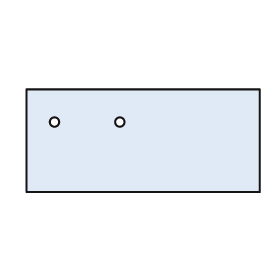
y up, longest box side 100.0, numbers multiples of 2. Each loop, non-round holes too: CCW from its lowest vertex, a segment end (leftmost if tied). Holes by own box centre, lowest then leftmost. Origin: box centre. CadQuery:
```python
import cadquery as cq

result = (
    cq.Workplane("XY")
    .moveTo(-50.0, -22.0)
    .lineTo(50.0, -22.0)
    .lineTo(50.0, 22.0)
    .lineTo(-50.0, 22.0)
    .close()
    .moveTo(-38.0, 8.0)
    .circle(2.0)
    .moveTo(-10.0, 8.0)
    .circle(2.0)
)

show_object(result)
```